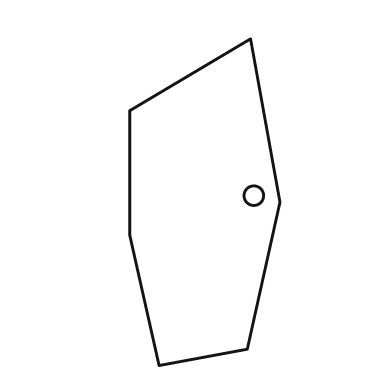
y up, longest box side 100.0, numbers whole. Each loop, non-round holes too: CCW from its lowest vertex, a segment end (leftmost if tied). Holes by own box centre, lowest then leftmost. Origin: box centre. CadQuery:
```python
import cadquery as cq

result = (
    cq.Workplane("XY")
    .moveTo(-14.0, -50.0)
    .lineTo(13.0, -45.0)
    .lineTo(23.0, 0.0)
    .lineTo(14.0, 50.0)
    .lineTo(-23.0, 28.0)
    .lineTo(-23.0, -10.0)
    .close()
    .moveTo(15.0, 2.0)
    .circle(3.0)
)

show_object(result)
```